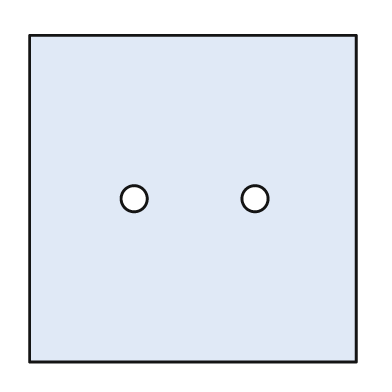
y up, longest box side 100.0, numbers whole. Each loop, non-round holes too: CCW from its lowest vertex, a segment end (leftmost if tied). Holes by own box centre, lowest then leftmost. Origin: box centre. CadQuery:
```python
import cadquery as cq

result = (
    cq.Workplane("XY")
    .moveTo(-50.0, -50.0)
    .lineTo(50.0, -50.0)
    .lineTo(50.0, 50.0)
    .lineTo(-50.0, 50.0)
    .close()
    .moveTo(-18.0, 0.0)
    .circle(4.0)
    .moveTo(19.0, 0.0)
    .circle(4.0)
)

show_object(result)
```